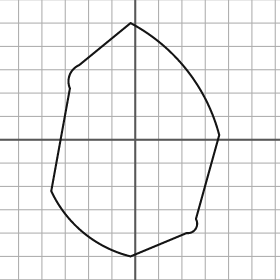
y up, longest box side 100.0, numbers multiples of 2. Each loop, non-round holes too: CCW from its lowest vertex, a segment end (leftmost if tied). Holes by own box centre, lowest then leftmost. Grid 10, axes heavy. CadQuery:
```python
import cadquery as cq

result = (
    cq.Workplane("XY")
    .moveTo(-2.0, -50.0)
    .lineTo(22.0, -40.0)
    .threePointArc((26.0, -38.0), (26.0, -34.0))
    .lineTo(36.0, 2.0)
    .threePointArc((22.0, 30.0), (-2.0, 50.0))
    .lineTo(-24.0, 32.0)
    .threePointArc((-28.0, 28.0), (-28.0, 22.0))
    .lineTo(-36.0, -22.0)
    .threePointArc((-22.0, -40.0), (-2.0, -50.0))
    .close()
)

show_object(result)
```